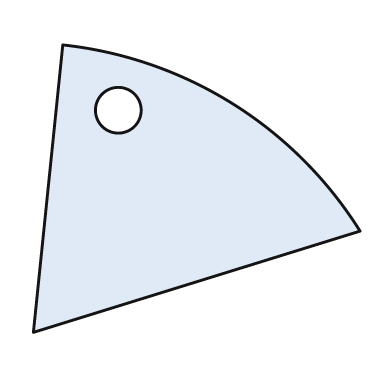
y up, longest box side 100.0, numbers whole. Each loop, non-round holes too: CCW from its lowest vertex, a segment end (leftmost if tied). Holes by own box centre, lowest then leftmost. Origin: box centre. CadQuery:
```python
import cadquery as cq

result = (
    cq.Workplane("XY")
    .moveTo(-50.0, -44.0)
    .lineTo(50.0, -13.0)
    .threePointArc((11.0, 26.0), (-41.0, 44.0))
    .close()
    .moveTo(-24.0, 24.0)
    .circle(7.0)
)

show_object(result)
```